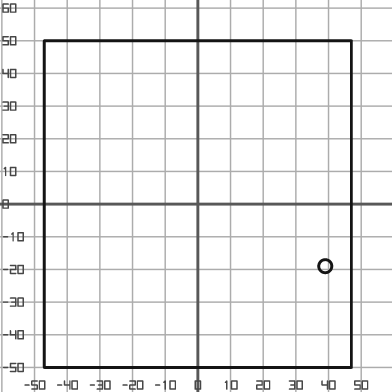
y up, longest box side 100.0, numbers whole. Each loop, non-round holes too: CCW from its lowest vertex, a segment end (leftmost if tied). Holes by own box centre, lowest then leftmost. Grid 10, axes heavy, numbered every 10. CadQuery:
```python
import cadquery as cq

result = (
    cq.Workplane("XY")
    .moveTo(-47.0, -50.0)
    .lineTo(47.0, -50.0)
    .lineTo(47.0, 50.0)
    .lineTo(-47.0, 50.0)
    .close()
    .moveTo(39.0, -19.0)
    .circle(2.0)
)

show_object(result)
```